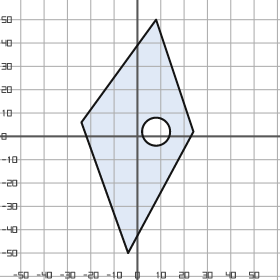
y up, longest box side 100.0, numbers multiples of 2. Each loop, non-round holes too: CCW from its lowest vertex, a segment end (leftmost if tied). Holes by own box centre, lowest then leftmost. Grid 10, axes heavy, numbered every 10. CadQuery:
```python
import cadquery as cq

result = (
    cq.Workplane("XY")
    .moveTo(-4.0, -50.0)
    .lineTo(24.0, 2.0)
    .lineTo(8.0, 50.0)
    .lineTo(-24.0, 6.0)
    .close()
    .moveTo(8.0, 2.0)
    .circle(6.0)
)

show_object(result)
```